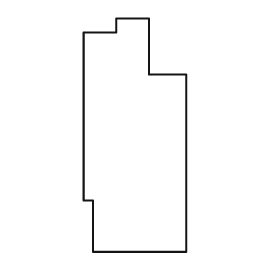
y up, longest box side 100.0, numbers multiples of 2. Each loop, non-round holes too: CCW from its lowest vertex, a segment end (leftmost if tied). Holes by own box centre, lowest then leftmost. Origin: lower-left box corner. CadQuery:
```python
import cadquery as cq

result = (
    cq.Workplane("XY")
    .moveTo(4.0, 0.0)
    .lineTo(44.0, 0.0)
    .lineTo(44.0, 76.0)
    .lineTo(28.0, 76.0)
    .lineTo(28.0, 100.0)
    .lineTo(14.0, 100.0)
    .lineTo(14.0, 94.0)
    .lineTo(0.0, 94.0)
    .lineTo(0.0, 22.0)
    .lineTo(4.0, 22.0)
    .close()
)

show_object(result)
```